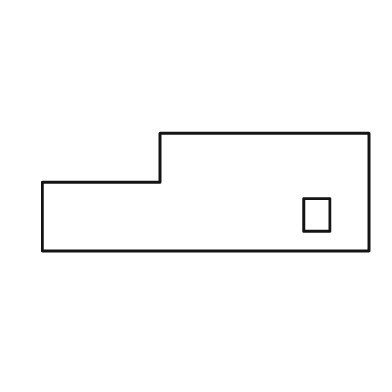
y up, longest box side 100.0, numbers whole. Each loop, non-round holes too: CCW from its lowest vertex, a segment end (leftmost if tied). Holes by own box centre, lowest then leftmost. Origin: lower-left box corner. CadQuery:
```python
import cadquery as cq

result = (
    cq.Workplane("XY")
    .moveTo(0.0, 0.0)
    .lineTo(100.0, 0.0)
    .lineTo(100.0, 36.0)
    .lineTo(36.0, 36.0)
    .lineTo(36.0, 21.0)
    .lineTo(0.0, 21.0)
    .close()
    .moveTo(80.0, 6.0)
    .lineTo(88.0, 6.0)
    .lineTo(88.0, 16.0)
    .lineTo(80.0, 16.0)
    .close()
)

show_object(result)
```